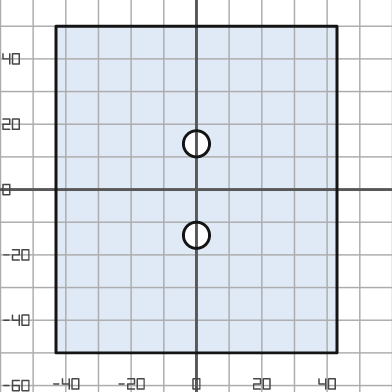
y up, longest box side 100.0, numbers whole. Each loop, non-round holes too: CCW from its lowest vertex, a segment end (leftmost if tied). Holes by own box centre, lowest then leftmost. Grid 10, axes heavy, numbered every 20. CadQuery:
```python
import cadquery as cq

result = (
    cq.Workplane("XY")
    .moveTo(-43.0, -50.0)
    .lineTo(43.0, -50.0)
    .lineTo(43.0, 50.0)
    .lineTo(-43.0, 50.0)
    .close()
    .moveTo(0.0, -14.0)
    .circle(4.0)
    .moveTo(0.0, 14.0)
    .circle(4.0)
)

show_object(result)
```